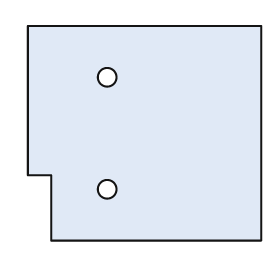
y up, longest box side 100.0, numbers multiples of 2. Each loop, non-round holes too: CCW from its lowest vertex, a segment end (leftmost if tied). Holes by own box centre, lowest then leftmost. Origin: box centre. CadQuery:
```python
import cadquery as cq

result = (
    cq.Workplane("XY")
    .moveTo(-40.0, -46.0)
    .lineTo(50.0, -46.0)
    .lineTo(50.0, 46.0)
    .lineTo(-50.0, 46.0)
    .lineTo(-50.0, -18.0)
    .lineTo(-40.0, -18.0)
    .close()
    .moveTo(-16.0, -24.0)
    .circle(4.0)
    .moveTo(-16.0, 24.0)
    .circle(4.0)
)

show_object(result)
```